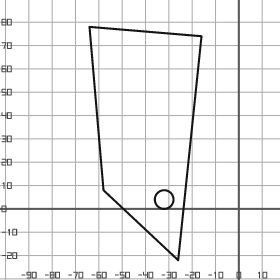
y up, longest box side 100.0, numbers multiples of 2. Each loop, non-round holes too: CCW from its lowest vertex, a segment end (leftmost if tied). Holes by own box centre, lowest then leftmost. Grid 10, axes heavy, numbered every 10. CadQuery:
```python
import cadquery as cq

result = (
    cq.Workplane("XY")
    .moveTo(-26.0, -22.0)
    .lineTo(-16.0, 74.0)
    .lineTo(-64.0, 78.0)
    .lineTo(-58.0, 8.0)
    .close()
    .moveTo(-32.0, 4.0)
    .circle(4.0)
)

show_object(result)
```